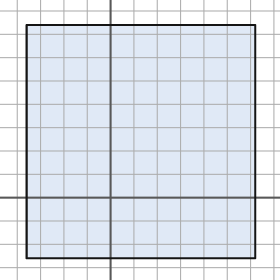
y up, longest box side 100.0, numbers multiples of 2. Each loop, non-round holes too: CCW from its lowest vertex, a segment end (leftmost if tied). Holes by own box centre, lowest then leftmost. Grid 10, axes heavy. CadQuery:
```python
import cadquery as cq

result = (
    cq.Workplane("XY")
    .moveTo(-36.0, -26.0)
    .lineTo(62.0, -26.0)
    .lineTo(62.0, 74.0)
    .lineTo(-36.0, 74.0)
    .close()
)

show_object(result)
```